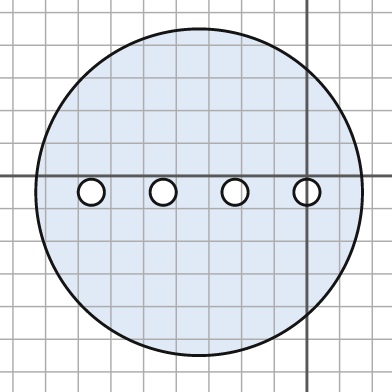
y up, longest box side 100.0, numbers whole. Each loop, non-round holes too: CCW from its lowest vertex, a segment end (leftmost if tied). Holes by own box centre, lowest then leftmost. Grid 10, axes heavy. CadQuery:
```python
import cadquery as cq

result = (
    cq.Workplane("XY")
    .moveTo(-33.0, -5.0)
    .circle(50.0)
    .moveTo(-66.0, -5.0)
    .circle(4.0)
    .moveTo(-44.0, -5.0)
    .circle(4.0)
    .moveTo(-22.0, -5.0)
    .circle(4.0)
    .moveTo(0.0, -5.0)
    .circle(4.0)
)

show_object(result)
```